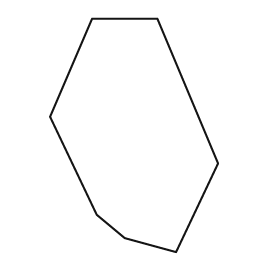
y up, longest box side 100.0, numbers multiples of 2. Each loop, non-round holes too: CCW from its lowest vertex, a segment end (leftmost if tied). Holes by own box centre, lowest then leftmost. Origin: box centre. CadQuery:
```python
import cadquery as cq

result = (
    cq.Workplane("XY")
    .moveTo(18.0, -50.0)
    .lineTo(36.0, -12.0)
    .lineTo(10.0, 50.0)
    .lineTo(-18.0, 50.0)
    .lineTo(-36.0, 8.0)
    .lineTo(-16.0, -34.0)
    .lineTo(-4.0, -44.0)
    .close()
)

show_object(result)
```